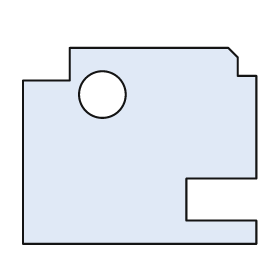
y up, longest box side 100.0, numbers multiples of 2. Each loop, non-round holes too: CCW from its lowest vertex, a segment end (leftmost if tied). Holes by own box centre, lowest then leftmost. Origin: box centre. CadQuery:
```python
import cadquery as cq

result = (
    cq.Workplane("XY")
    .moveTo(-50.0, -42.0)
    .lineTo(50.0, -42.0)
    .lineTo(50.0, -32.0)
    .lineTo(20.0, -32.0)
    .lineTo(20.0, -14.0)
    .lineTo(50.0, -14.0)
    .lineTo(50.0, 30.0)
    .lineTo(42.0, 30.0)
    .lineTo(42.0, 38.0)
    .lineTo(38.0, 42.0)
    .lineTo(-30.0, 42.0)
    .lineTo(-30.0, 28.0)
    .lineTo(-50.0, 28.0)
    .close()
    .moveTo(-16.0, 22.0)
    .circle(10.0)
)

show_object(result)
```